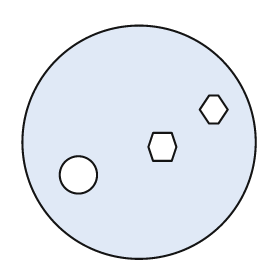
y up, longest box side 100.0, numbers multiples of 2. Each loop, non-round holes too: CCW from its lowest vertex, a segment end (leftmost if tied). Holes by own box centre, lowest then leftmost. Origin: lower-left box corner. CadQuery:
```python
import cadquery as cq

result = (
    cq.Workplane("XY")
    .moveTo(50.0, 50.0)
    .circle(50.0)
    .moveTo(24.0, 36.0)
    .circle(8.0)
    .moveTo(56.0, 42.0)
    .lineTo(64.0, 42.0)
    .lineTo(66.0, 48.0)
    .lineTo(64.0, 54.0)
    .lineTo(56.0, 54.0)
    .lineTo(54.0, 48.0)
    .close()
    .moveTo(80.0, 58.0)
    .lineTo(84.0, 58.0)
    .lineTo(88.0, 64.0)
    .lineTo(84.0, 70.0)
    .lineTo(80.0, 70.0)
    .lineTo(76.0, 64.0)
    .close()
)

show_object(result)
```